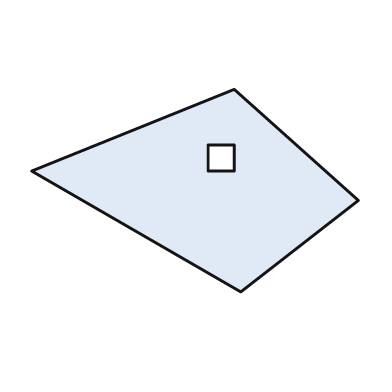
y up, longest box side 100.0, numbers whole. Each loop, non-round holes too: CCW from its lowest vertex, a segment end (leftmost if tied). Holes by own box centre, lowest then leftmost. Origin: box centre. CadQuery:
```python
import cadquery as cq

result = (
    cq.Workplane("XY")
    .moveTo(14.0, -31.0)
    .lineTo(50.0, -3.0)
    .lineTo(12.0, 31.0)
    .lineTo(-50.0, 6.0)
    .close()
    .moveTo(4.0, 6.0)
    .lineTo(12.0, 6.0)
    .lineTo(12.0, 14.0)
    .lineTo(4.0, 14.0)
    .close()
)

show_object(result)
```